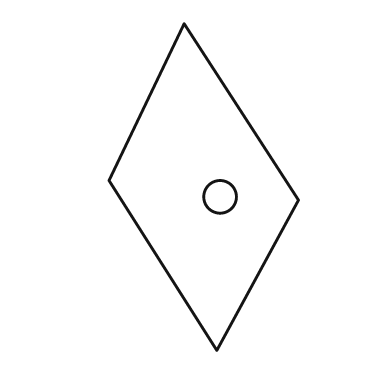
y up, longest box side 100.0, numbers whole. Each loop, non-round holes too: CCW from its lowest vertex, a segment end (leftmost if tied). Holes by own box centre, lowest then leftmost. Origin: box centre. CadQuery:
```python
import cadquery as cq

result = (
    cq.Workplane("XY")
    .moveTo(4.0, -50.0)
    .lineTo(29.0, -4.0)
    .lineTo(-6.0, 50.0)
    .lineTo(-29.0, 2.0)
    .close()
    .moveTo(5.0, -3.0)
    .circle(5.0)
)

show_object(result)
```